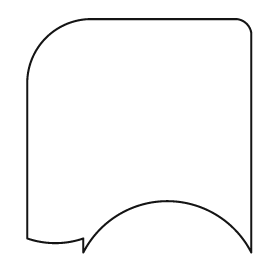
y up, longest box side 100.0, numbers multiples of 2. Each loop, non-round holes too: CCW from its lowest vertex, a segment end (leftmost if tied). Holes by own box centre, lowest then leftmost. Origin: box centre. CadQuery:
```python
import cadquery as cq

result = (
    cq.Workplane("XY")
    .moveTo(-24.0, -50.0)
    .threePointArc((12.0, -28.0), (48.0, -50.0))
    .lineTo(48.0, 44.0)
    .threePointArc((46.0, 48.0), (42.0, 50.0))
    .lineTo(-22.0, 50.0)
    .threePointArc((-40.0, 42.0), (-48.0, 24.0))
    .lineTo(-48.0, -44.0)
    .threePointArc((-36.0, -46.0), (-24.0, -44.0))
    .close()
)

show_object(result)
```